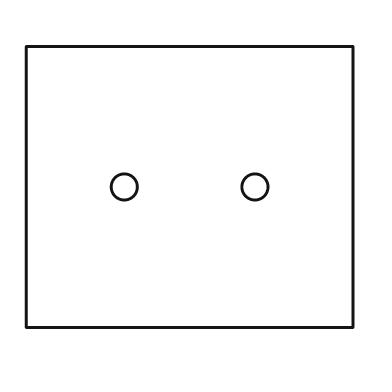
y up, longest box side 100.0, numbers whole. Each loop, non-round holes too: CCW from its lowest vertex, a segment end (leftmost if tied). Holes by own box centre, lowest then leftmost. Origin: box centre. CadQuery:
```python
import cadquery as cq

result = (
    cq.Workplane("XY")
    .moveTo(-50.0, -43.0)
    .lineTo(50.0, -43.0)
    .lineTo(50.0, 43.0)
    .lineTo(-50.0, 43.0)
    .close()
    .moveTo(-20.0, 0.0)
    .circle(4.0)
    .moveTo(20.0, 0.0)
    .circle(4.0)
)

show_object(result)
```